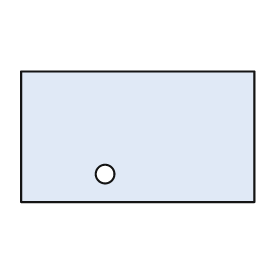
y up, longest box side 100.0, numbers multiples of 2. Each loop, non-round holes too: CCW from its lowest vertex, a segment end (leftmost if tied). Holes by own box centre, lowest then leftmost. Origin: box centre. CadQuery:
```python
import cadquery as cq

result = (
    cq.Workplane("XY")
    .moveTo(-50.0, -28.0)
    .lineTo(50.0, -28.0)
    .lineTo(50.0, 28.0)
    .lineTo(-50.0, 28.0)
    .close()
    .moveTo(-14.0, -16.0)
    .circle(4.0)
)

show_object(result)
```